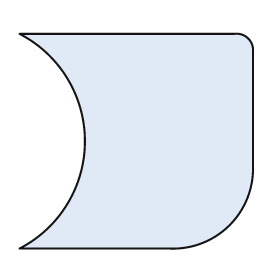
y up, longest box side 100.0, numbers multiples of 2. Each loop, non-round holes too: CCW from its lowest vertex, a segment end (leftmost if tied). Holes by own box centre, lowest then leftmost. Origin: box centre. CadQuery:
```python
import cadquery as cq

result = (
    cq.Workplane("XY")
    .moveTo(-50.0, -46.0)
    .lineTo(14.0, -46.0)
    .threePointArc((40.0, -36.0), (50.0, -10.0))
    .lineTo(50.0, 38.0)
    .threePointArc((48.0, 44.0), (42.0, 46.0))
    .lineTo(-50.0, 46.0)
    .threePointArc((-22.0, 0.0), (-50.0, -46.0))
    .close()
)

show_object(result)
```